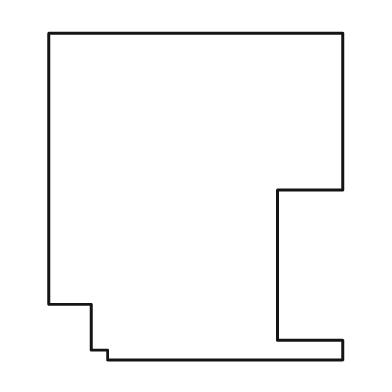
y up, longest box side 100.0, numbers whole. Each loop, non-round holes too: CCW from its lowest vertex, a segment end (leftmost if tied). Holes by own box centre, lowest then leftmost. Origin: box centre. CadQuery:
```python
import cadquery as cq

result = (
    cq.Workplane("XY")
    .moveTo(-27.0, -50.0)
    .lineTo(45.0, -50.0)
    .lineTo(45.0, -44.0)
    .lineTo(25.0, -44.0)
    .lineTo(25.0, 2.0)
    .lineTo(45.0, 2.0)
    .lineTo(45.0, 50.0)
    .lineTo(-45.0, 50.0)
    .lineTo(-45.0, -33.0)
    .lineTo(-32.0, -33.0)
    .lineTo(-32.0, -47.0)
    .lineTo(-27.0, -47.0)
    .close()
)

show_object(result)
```